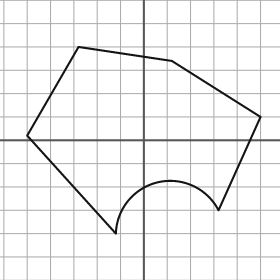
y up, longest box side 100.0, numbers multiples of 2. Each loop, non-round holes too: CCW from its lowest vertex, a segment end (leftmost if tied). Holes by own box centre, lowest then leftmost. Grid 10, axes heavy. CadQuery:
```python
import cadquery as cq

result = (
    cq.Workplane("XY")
    .moveTo(-12.0, -40.0)
    .threePointArc((6.0, -18.0), (32.0, -30.0))
    .lineTo(50.0, 10.0)
    .lineTo(12.0, 34.0)
    .lineTo(-28.0, 40.0)
    .lineTo(-50.0, 2.0)
    .close()
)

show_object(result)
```